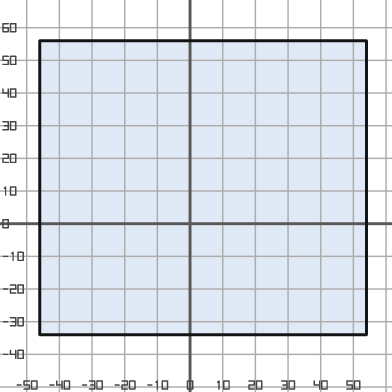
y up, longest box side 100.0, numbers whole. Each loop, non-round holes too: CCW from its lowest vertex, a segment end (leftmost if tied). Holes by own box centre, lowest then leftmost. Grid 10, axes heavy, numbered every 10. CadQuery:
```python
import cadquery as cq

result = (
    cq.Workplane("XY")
    .moveTo(-46.0, -34.0)
    .lineTo(54.0, -34.0)
    .lineTo(54.0, 56.0)
    .lineTo(-46.0, 56.0)
    .close()
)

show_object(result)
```